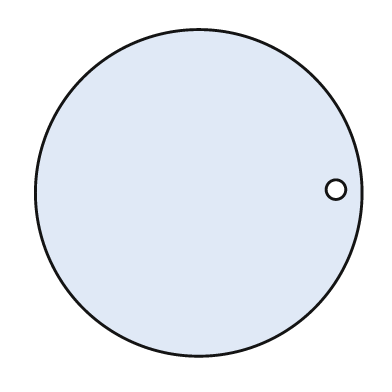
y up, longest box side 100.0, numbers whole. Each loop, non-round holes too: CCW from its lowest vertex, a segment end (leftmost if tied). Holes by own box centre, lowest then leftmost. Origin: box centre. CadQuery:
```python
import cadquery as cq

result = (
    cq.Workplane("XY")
    .moveTo(0.0, 0.0)
    .circle(50.0)
    .moveTo(42.0, 1.0)
    .circle(3.0)
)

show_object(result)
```